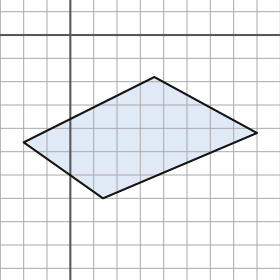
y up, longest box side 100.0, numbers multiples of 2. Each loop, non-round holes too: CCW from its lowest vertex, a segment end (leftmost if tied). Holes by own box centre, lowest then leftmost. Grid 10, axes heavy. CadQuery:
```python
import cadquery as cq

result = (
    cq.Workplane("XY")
    .moveTo(14.0, -70.0)
    .lineTo(80.0, -42.0)
    .lineTo(36.0, -18.0)
    .lineTo(-20.0, -46.0)
    .close()
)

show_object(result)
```